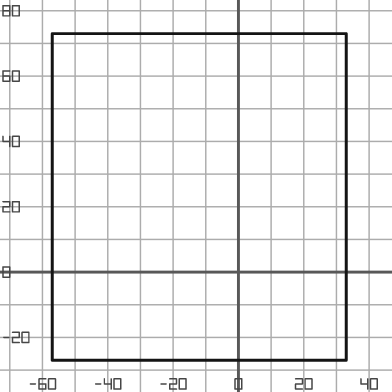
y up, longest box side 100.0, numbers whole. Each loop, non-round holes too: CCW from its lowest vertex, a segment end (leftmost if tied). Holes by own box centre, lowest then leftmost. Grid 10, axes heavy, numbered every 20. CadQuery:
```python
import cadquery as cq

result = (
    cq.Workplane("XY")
    .moveTo(-57.0, -27.0)
    .lineTo(33.0, -27.0)
    .lineTo(33.0, 73.0)
    .lineTo(-57.0, 73.0)
    .close()
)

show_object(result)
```